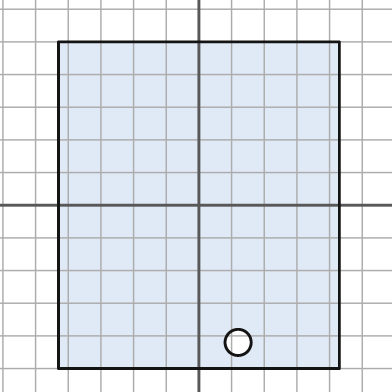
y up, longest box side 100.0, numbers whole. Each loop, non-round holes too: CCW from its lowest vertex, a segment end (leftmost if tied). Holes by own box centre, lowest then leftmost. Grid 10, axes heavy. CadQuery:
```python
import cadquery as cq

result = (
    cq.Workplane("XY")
    .moveTo(-43.0, -50.0)
    .lineTo(43.0, -50.0)
    .lineTo(43.0, 50.0)
    .lineTo(-43.0, 50.0)
    .close()
    .moveTo(12.0, -42.0)
    .circle(4.0)
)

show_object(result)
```